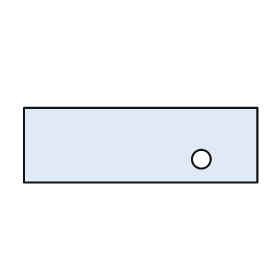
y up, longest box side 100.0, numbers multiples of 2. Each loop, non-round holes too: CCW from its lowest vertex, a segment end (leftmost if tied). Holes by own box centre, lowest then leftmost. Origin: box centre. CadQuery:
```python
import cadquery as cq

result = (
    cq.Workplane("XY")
    .moveTo(-50.0, -16.0)
    .lineTo(50.0, -16.0)
    .lineTo(50.0, 16.0)
    .lineTo(-50.0, 16.0)
    .close()
    .moveTo(26.0, -6.0)
    .circle(4.0)
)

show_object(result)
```